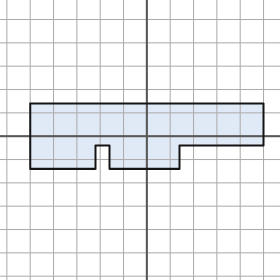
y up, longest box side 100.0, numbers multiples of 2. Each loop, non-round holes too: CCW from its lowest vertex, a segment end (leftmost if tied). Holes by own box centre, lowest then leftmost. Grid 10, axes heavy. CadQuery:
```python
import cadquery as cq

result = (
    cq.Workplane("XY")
    .moveTo(-50.0, -14.0)
    .lineTo(-22.0, -14.0)
    .lineTo(-22.0, -4.0)
    .lineTo(-16.0, -4.0)
    .lineTo(-16.0, -14.0)
    .lineTo(14.0, -14.0)
    .lineTo(14.0, -4.0)
    .lineTo(50.0, -4.0)
    .lineTo(50.0, 14.0)
    .lineTo(-50.0, 14.0)
    .close()
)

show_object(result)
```